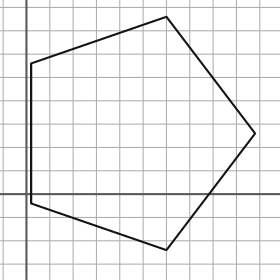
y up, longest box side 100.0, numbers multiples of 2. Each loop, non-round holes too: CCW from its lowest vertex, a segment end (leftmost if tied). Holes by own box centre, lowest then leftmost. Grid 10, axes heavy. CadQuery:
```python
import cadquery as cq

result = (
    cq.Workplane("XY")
    .moveTo(60.0, -24.0)
    .lineTo(98.0, 26.0)
    .lineTo(60.0, 76.0)
    .lineTo(2.0, 56.0)
    .lineTo(2.0, -4.0)
    .close()
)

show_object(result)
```